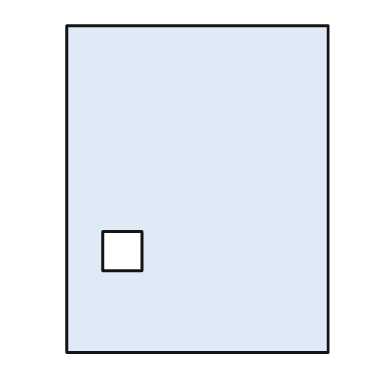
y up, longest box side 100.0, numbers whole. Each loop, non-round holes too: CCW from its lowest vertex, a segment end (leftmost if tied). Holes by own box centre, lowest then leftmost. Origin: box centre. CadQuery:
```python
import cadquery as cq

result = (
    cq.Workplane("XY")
    .moveTo(-40.0, -50.0)
    .lineTo(40.0, -50.0)
    .lineTo(40.0, 50.0)
    .lineTo(-40.0, 50.0)
    .close()
    .moveTo(-29.0, -25.0)
    .lineTo(-17.0, -25.0)
    .lineTo(-17.0, -13.0)
    .lineTo(-29.0, -13.0)
    .close()
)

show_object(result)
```